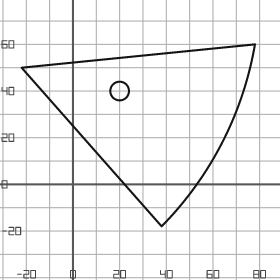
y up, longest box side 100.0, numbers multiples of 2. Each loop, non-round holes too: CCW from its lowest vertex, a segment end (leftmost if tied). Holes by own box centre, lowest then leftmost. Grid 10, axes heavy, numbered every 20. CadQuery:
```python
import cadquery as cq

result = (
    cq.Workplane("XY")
    .moveTo(38.0, -18.0)
    .threePointArc((64.0, 18.0), (78.0, 60.0))
    .lineTo(-22.0, 50.0)
    .close()
    .moveTo(20.0, 40.0)
    .circle(4.0)
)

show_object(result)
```